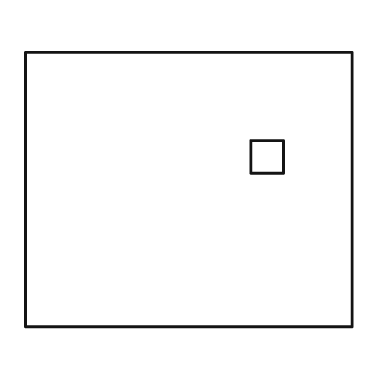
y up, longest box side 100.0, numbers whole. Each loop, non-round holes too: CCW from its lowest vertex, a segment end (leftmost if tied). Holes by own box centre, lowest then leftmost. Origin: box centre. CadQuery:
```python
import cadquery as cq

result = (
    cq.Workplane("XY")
    .moveTo(-50.0, -42.0)
    .lineTo(50.0, -42.0)
    .lineTo(50.0, 42.0)
    .lineTo(-50.0, 42.0)
    .close()
    .moveTo(19.0, 5.0)
    .lineTo(29.0, 5.0)
    .lineTo(29.0, 15.0)
    .lineTo(19.0, 15.0)
    .close()
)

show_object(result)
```